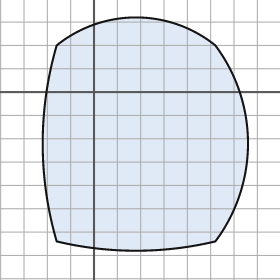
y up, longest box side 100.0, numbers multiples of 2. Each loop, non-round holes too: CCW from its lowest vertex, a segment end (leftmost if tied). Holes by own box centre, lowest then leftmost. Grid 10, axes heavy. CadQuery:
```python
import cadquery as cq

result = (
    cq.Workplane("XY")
    .moveTo(-16.0, -64.0)
    .threePointArc((18.0, -68.0), (52.0, -64.0))
    .threePointArc((66.0, -22.0), (52.0, 20.0))
    .threePointArc((18.0, 32.0), (-16.0, 20.0))
    .threePointArc((-22.0, -22.0), (-16.0, -64.0))
    .close()
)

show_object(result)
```